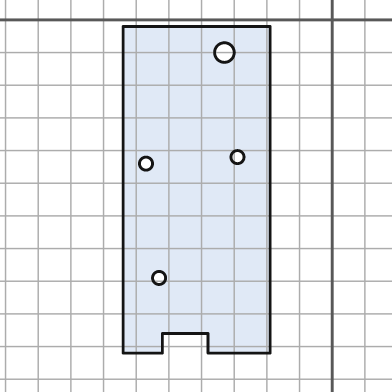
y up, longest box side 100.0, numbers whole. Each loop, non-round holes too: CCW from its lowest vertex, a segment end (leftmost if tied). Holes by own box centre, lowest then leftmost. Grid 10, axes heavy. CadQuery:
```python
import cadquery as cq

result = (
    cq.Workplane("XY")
    .moveTo(-64.0, -102.0)
    .lineTo(-52.0, -102.0)
    .lineTo(-52.0, -96.0)
    .lineTo(-38.0, -96.0)
    .lineTo(-38.0, -102.0)
    .lineTo(-19.0, -102.0)
    .lineTo(-19.0, -2.0)
    .lineTo(-64.0, -2.0)
    .close()
    .moveTo(-53.0, -79.0)
    .circle(2.0)
    .moveTo(-57.0, -44.0)
    .circle(2.0)
    .moveTo(-29.0, -42.0)
    .circle(2.0)
    .moveTo(-33.0, -10.0)
    .circle(3.0)
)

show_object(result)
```